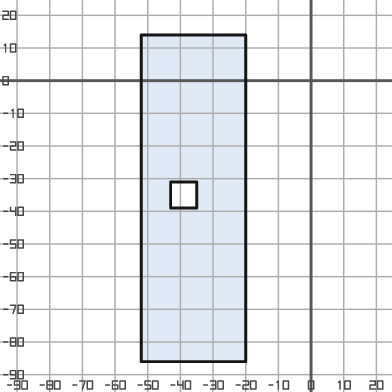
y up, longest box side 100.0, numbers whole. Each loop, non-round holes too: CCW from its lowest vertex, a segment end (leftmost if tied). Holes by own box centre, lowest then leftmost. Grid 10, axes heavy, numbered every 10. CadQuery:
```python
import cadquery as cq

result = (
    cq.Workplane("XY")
    .moveTo(-52.0, -86.0)
    .lineTo(-20.0, -86.0)
    .lineTo(-20.0, 14.0)
    .lineTo(-52.0, 14.0)
    .close()
    .moveTo(-43.0, -39.0)
    .lineTo(-35.0, -39.0)
    .lineTo(-35.0, -31.0)
    .lineTo(-43.0, -31.0)
    .close()
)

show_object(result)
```